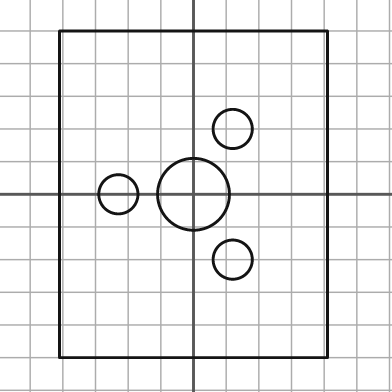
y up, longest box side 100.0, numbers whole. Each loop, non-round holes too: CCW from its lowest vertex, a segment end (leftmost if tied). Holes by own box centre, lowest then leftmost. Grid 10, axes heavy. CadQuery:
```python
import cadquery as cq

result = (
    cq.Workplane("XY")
    .moveTo(-41.0, -50.0)
    .lineTo(41.0, -50.0)
    .lineTo(41.0, 50.0)
    .lineTo(-41.0, 50.0)
    .close()
    .moveTo(12.0, -20.0)
    .circle(6.0)
    .moveTo(-23.0, 0.0)
    .circle(6.0)
    .moveTo(0.0, 0.0)
    .circle(11.0)
    .moveTo(12.0, 20.0)
    .circle(6.0)
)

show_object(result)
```